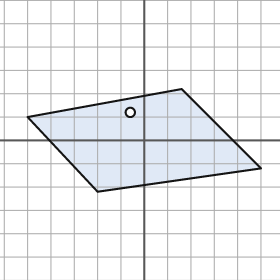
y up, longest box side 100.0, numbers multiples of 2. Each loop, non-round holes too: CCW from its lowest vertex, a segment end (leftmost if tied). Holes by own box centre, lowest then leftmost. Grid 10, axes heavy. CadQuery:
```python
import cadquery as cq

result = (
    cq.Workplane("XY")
    .moveTo(-20.0, -22.0)
    .lineTo(50.0, -12.0)
    .lineTo(16.0, 22.0)
    .lineTo(-50.0, 10.0)
    .close()
    .moveTo(-6.0, 12.0)
    .circle(2.0)
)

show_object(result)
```